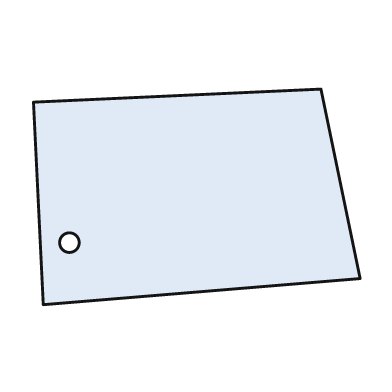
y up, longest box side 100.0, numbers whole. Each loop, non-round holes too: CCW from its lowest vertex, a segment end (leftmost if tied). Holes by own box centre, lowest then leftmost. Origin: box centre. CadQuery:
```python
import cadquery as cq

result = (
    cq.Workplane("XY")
    .moveTo(-47.0, -33.0)
    .lineTo(50.0, -25.0)
    .lineTo(38.0, 33.0)
    .lineTo(-50.0, 29.0)
    .close()
    .moveTo(-39.0, -14.0)
    .circle(3.0)
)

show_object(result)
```